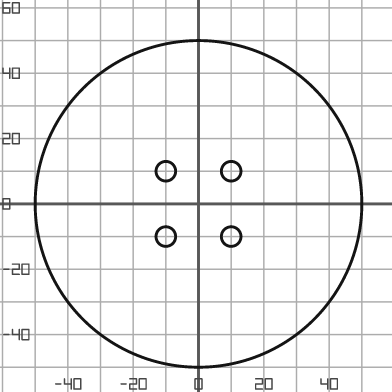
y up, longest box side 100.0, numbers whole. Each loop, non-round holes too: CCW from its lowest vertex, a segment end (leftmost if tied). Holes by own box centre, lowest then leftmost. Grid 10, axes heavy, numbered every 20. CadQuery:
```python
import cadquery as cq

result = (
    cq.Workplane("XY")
    .moveTo(0.0, 0.0)
    .circle(50.0)
    .moveTo(-10.0, -10.0)
    .circle(3.0)
    .moveTo(10.0, -10.0)
    .circle(3.0)
    .moveTo(-10.0, 10.0)
    .circle(3.0)
    .moveTo(10.0, 10.0)
    .circle(3.0)
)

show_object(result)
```